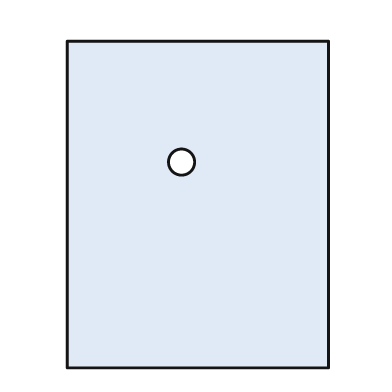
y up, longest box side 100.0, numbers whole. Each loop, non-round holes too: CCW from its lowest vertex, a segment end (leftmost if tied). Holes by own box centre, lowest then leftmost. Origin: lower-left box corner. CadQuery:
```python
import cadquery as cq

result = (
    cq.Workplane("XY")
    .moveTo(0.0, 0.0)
    .lineTo(80.0, 0.0)
    .lineTo(80.0, 100.0)
    .lineTo(0.0, 100.0)
    .close()
    .moveTo(35.0, 63.0)
    .circle(4.0)
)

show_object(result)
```